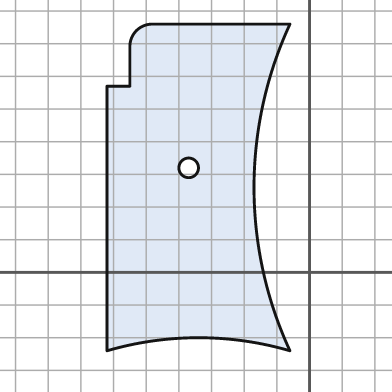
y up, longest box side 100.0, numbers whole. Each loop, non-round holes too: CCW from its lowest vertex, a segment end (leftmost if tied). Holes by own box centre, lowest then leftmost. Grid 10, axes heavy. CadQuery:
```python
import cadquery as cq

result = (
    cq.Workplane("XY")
    .moveTo(-62.0, -24.0)
    .threePointArc((-34.0, -20.0), (-6.0, -24.0))
    .threePointArc((-17.0, 26.0), (-6.0, 76.0))
    .lineTo(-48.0, 76.0)
    .threePointArc((-53.0, 74.0), (-55.0, 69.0))
    .lineTo(-55.0, 57.0)
    .lineTo(-62.0, 57.0)
    .close()
    .moveTo(-37.0, 32.0)
    .circle(3.0)
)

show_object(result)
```